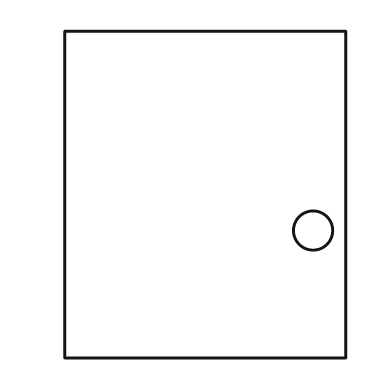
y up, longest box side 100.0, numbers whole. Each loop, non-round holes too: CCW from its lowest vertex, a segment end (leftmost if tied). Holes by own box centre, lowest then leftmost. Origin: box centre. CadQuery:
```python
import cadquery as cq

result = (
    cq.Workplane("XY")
    .moveTo(-43.0, -50.0)
    .lineTo(43.0, -50.0)
    .lineTo(43.0, 50.0)
    .lineTo(-43.0, 50.0)
    .close()
    .moveTo(33.0, -11.0)
    .circle(6.0)
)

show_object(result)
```